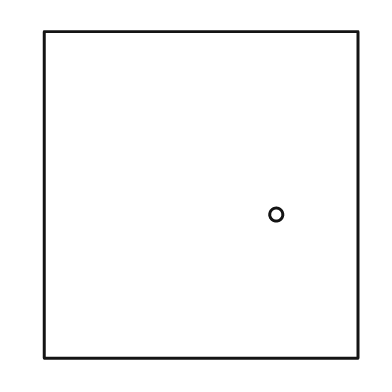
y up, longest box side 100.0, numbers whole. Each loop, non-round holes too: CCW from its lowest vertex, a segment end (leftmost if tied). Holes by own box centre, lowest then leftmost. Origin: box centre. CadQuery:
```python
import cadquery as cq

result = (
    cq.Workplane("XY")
    .moveTo(-48.0, -50.0)
    .lineTo(48.0, -50.0)
    .lineTo(48.0, 50.0)
    .lineTo(-48.0, 50.0)
    .close()
    .moveTo(23.0, -6.0)
    .circle(2.0)
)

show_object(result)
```